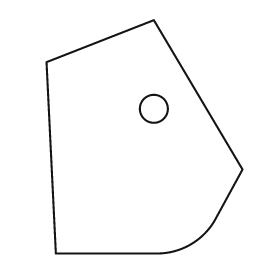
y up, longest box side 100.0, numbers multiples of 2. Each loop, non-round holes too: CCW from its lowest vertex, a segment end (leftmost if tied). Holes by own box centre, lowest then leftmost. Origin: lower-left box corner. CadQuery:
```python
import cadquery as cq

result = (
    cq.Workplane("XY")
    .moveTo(4.0, 0.0)
    .lineTo(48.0, 0.0)
    .threePointArc((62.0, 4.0), (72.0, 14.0))
    .lineTo(84.0, 36.0)
    .lineTo(46.0, 100.0)
    .lineTo(0.0, 82.0)
    .close()
    .moveTo(46.0, 62.0)
    .circle(6.0)
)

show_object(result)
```